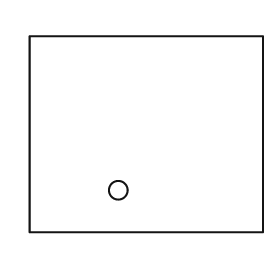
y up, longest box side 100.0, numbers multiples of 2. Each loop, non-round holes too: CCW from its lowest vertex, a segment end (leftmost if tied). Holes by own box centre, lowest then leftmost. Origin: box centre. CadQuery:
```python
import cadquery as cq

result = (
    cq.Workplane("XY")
    .moveTo(-50.0, -42.0)
    .lineTo(50.0, -42.0)
    .lineTo(50.0, 42.0)
    .lineTo(-50.0, 42.0)
    .close()
    .moveTo(-12.0, -24.0)
    .circle(4.0)
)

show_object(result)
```